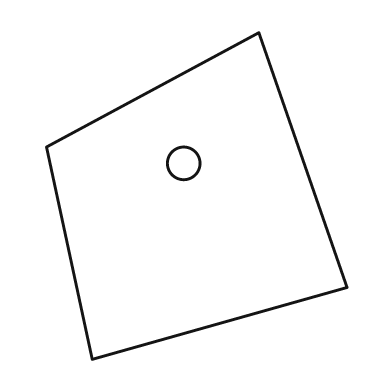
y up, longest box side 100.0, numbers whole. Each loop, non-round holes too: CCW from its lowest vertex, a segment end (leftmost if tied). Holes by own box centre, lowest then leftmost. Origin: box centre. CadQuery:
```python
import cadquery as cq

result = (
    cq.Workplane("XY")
    .moveTo(-32.0, -50.0)
    .lineTo(46.0, -28.0)
    .lineTo(19.0, 50.0)
    .lineTo(-46.0, 15.0)
    .close()
    .moveTo(-4.0, 10.0)
    .circle(5.0)
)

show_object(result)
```